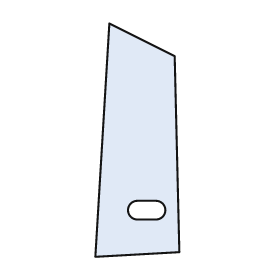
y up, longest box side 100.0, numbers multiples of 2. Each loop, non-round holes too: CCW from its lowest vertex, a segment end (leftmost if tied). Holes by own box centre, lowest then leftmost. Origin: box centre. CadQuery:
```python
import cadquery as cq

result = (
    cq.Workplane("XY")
    .moveTo(-18.0, -50.0)
    .lineTo(18.0, -48.0)
    .lineTo(16.0, 36.0)
    .lineTo(-12.0, 50.0)
    .close()
    .moveTo(0.0, -34.0)
    .lineTo(8.0, -34.0)
    .threePointArc((12.0, -30.0), (8.0, -26.0))
    .lineTo(0.0, -26.0)
    .threePointArc((-4.0, -30.0), (0.0, -34.0))
    .close()
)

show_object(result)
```